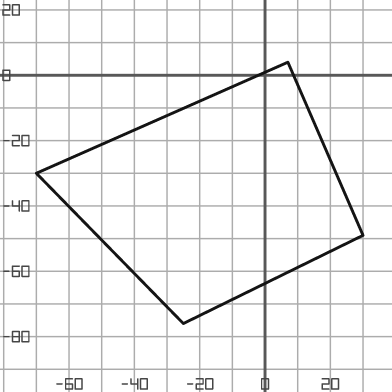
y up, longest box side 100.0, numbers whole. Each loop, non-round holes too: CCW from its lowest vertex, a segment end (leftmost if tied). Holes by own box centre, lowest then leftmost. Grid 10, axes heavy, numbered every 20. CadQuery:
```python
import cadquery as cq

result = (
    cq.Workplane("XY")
    .moveTo(-25.0, -76.0)
    .lineTo(30.0, -49.0)
    .lineTo(7.0, 4.0)
    .lineTo(-70.0, -30.0)
    .close()
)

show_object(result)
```